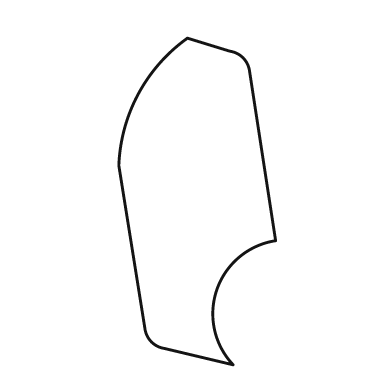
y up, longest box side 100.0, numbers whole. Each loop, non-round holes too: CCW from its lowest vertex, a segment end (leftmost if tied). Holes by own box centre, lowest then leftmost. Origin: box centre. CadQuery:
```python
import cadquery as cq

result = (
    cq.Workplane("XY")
    .moveTo(11.0, -50.0)
    .threePointArc((6.0, -27.0), (24.0, -12.0))
    .lineTo(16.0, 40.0)
    .threePointArc((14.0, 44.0), (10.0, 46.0))
    .lineTo(-3.0, 50.0)
    .threePointArc((-18.0, 33.0), (-24.0, 11.0))
    .lineTo(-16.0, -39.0)
    .threePointArc((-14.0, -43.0), (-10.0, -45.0))
    .close()
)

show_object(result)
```